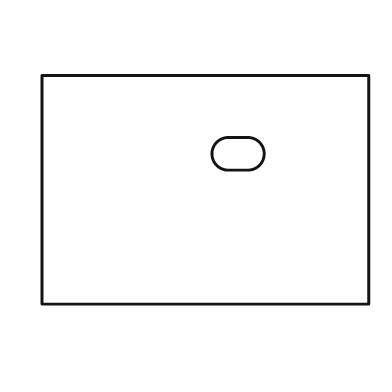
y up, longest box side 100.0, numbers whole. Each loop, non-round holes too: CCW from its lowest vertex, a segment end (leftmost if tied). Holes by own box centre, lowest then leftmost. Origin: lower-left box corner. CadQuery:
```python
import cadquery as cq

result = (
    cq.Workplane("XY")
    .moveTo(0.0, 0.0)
    .lineTo(100.0, 0.0)
    .lineTo(100.0, 70.0)
    .lineTo(0.0, 70.0)
    .close()
    .moveTo(57.0, 41.0)
    .lineTo(63.0, 41.0)
    .threePointArc((68.0, 46.0), (63.0, 51.0))
    .lineTo(57.0, 51.0)
    .threePointArc((52.0, 46.0), (57.0, 41.0))
    .close()
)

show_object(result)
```